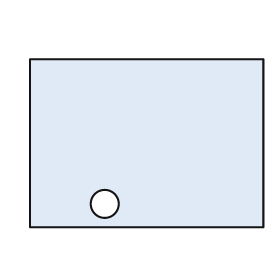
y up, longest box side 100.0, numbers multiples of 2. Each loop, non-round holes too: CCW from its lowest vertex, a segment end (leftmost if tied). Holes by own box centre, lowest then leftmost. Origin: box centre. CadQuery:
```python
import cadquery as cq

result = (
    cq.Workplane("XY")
    .moveTo(-50.0, -36.0)
    .lineTo(50.0, -36.0)
    .lineTo(50.0, 36.0)
    .lineTo(-50.0, 36.0)
    .close()
    .moveTo(-18.0, -26.0)
    .circle(6.0)
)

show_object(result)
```